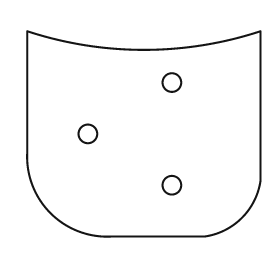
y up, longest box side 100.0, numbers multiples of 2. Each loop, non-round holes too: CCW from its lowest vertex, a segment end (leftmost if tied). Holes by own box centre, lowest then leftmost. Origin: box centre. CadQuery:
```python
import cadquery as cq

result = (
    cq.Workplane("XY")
    .moveTo(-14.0, -44.0)
    .lineTo(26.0, -44.0)
    .threePointArc((42.0, -36.0), (50.0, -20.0))
    .lineTo(50.0, 44.0)
    .threePointArc((0.0, 36.0), (-50.0, 44.0))
    .lineTo(-50.0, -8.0)
    .threePointArc((-40.0, -34.0), (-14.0, -44.0))
    .close()
    .moveTo(12.0, -22.0)
    .circle(4.0)
    .moveTo(-24.0, 0.0)
    .circle(4.0)
    .moveTo(12.0, 22.0)
    .circle(4.0)
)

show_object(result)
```